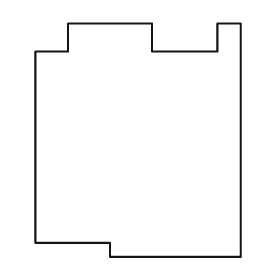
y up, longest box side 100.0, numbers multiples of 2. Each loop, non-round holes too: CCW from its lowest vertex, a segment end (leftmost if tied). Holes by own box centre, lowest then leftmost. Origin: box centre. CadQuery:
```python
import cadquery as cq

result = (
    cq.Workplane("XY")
    .moveTo(-12.0, -50.0)
    .lineTo(44.0, -50.0)
    .lineTo(44.0, 50.0)
    .lineTo(34.0, 50.0)
    .lineTo(34.0, 38.0)
    .lineTo(6.0, 38.0)
    .lineTo(6.0, 50.0)
    .lineTo(-30.0, 50.0)
    .lineTo(-30.0, 38.0)
    .lineTo(-44.0, 38.0)
    .lineTo(-44.0, -44.0)
    .lineTo(-12.0, -44.0)
    .close()
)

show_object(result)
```